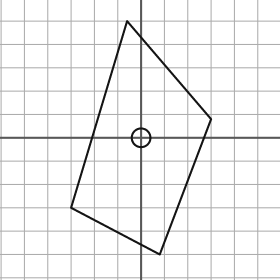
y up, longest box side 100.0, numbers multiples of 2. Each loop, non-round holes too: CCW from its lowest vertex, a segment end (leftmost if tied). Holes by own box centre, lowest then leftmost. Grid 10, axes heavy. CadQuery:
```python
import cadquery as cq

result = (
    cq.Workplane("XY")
    .moveTo(8.0, -50.0)
    .lineTo(30.0, 8.0)
    .lineTo(-6.0, 50.0)
    .lineTo(-30.0, -30.0)
    .close()
    .moveTo(0.0, 0.0)
    .circle(4.0)
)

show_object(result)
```